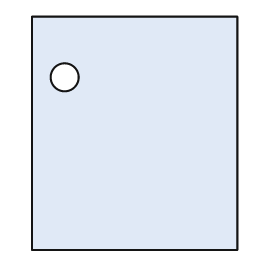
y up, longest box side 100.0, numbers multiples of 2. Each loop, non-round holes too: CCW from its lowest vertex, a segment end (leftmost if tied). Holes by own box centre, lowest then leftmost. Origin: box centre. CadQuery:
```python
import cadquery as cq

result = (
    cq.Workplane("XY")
    .moveTo(-44.0, -50.0)
    .lineTo(44.0, -50.0)
    .lineTo(44.0, 50.0)
    .lineTo(-44.0, 50.0)
    .close()
    .moveTo(-30.0, 24.0)
    .circle(6.0)
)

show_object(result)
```